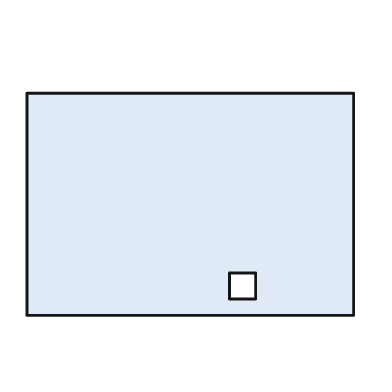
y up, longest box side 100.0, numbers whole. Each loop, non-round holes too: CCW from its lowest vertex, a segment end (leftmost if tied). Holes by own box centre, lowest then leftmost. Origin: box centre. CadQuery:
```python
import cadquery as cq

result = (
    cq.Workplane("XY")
    .moveTo(-50.0, -34.0)
    .lineTo(50.0, -34.0)
    .lineTo(50.0, 34.0)
    .lineTo(-50.0, 34.0)
    .close()
    .moveTo(12.0, -29.0)
    .lineTo(20.0, -29.0)
    .lineTo(20.0, -21.0)
    .lineTo(12.0, -21.0)
    .close()
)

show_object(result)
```